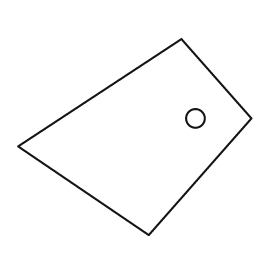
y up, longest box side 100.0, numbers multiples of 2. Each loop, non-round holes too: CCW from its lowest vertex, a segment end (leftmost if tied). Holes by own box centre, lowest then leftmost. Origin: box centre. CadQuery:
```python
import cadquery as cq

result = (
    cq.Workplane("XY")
    .moveTo(6.0, -42.0)
    .lineTo(50.0, 8.0)
    .lineTo(20.0, 42.0)
    .lineTo(-50.0, -4.0)
    .close()
    .moveTo(26.0, 8.0)
    .circle(4.0)
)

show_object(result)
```